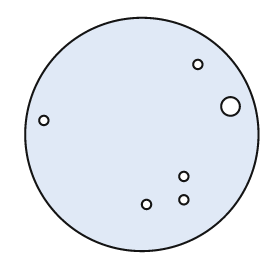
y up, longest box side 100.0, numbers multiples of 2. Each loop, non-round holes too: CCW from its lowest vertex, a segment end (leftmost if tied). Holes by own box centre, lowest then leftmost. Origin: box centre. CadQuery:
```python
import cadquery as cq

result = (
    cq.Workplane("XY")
    .moveTo(0.0, 0.0)
    .circle(50.0)
    .moveTo(2.0, -30.0)
    .circle(2.0)
    .moveTo(18.0, -28.0)
    .circle(2.0)
    .moveTo(18.0, -18.0)
    .circle(2.0)
    .moveTo(-42.0, 6.0)
    .circle(2.0)
    .moveTo(38.0, 12.0)
    .circle(4.0)
    .moveTo(24.0, 30.0)
    .circle(2.0)
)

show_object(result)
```